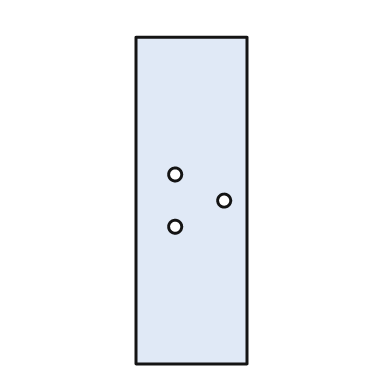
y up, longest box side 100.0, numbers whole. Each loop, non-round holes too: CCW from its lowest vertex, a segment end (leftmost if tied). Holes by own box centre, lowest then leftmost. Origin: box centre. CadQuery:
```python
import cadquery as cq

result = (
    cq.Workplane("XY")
    .moveTo(-17.0, -50.0)
    .lineTo(17.0, -50.0)
    .lineTo(17.0, 50.0)
    .lineTo(-17.0, 50.0)
    .close()
    .moveTo(-5.0, -8.0)
    .circle(2.0)
    .moveTo(10.0, 0.0)
    .circle(2.0)
    .moveTo(-5.0, 8.0)
    .circle(2.0)
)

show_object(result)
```